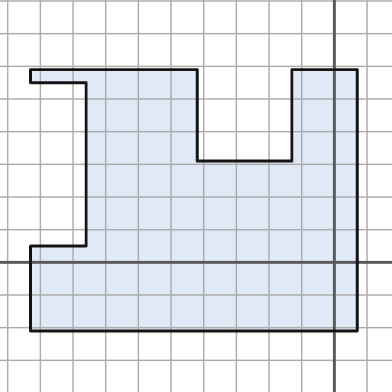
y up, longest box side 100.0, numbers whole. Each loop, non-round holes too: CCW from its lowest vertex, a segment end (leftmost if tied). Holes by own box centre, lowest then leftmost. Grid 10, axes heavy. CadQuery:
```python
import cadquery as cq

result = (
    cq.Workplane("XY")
    .moveTo(-93.0, -21.0)
    .lineTo(7.0, -21.0)
    .lineTo(7.0, 59.0)
    .lineTo(-13.0, 59.0)
    .lineTo(-13.0, 31.0)
    .lineTo(-42.0, 31.0)
    .lineTo(-42.0, 59.0)
    .lineTo(-93.0, 59.0)
    .lineTo(-93.0, 55.0)
    .lineTo(-76.0, 55.0)
    .lineTo(-76.0, 5.0)
    .lineTo(-93.0, 5.0)
    .close()
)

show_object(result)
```